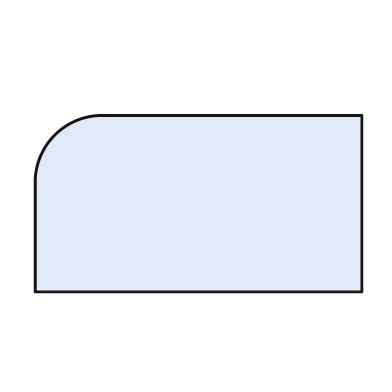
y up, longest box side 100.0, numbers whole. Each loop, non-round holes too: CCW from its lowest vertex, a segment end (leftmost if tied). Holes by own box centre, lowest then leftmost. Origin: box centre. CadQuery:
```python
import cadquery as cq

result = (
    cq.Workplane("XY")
    .moveTo(-50.0, -27.0)
    .lineTo(50.0, -27.0)
    .lineTo(50.0, 27.0)
    .lineTo(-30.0, 27.0)
    .threePointArc((-44.0, 21.0), (-50.0, 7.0))
    .close()
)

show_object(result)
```